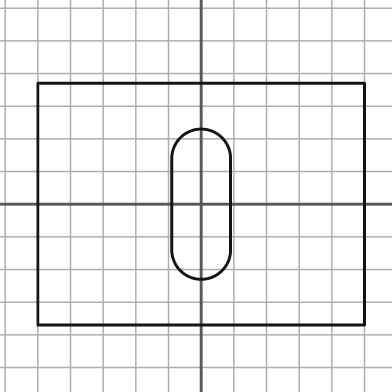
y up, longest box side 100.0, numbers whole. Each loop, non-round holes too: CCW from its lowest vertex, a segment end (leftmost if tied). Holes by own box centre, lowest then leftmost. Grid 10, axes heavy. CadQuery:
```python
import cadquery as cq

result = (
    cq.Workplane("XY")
    .moveTo(-50.0, -37.0)
    .lineTo(50.0, -37.0)
    .lineTo(50.0, 37.0)
    .lineTo(-50.0, 37.0)
    .close()
    .moveTo(-9.0, -14.0)
    .threePointArc((0.0, -23.0), (9.0, -14.0))
    .lineTo(9.0, 14.0)
    .threePointArc((0.0, 23.0), (-9.0, 14.0))
    .close()
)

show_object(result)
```